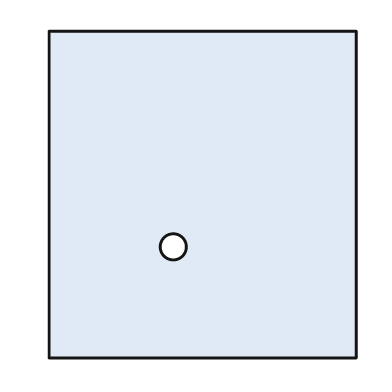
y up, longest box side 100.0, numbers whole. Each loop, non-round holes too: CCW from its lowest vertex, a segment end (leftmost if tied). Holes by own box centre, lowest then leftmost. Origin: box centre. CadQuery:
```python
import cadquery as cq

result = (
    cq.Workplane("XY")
    .moveTo(-47.0, -50.0)
    .lineTo(47.0, -50.0)
    .lineTo(47.0, 50.0)
    .lineTo(-47.0, 50.0)
    .close()
    .moveTo(-9.0, -16.0)
    .circle(4.0)
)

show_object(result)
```